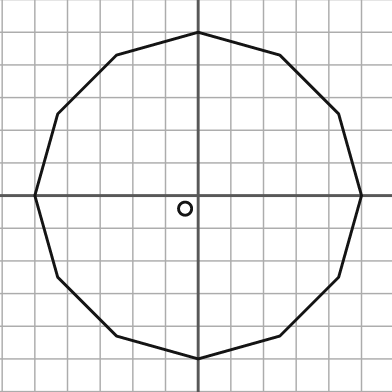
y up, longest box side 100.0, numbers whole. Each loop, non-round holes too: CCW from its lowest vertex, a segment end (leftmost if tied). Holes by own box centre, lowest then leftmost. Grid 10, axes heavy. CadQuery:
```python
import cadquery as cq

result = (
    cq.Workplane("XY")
    .moveTo(0.0, -50.0)
    .lineTo(25.0, -43.0)
    .lineTo(43.0, -25.0)
    .lineTo(50.0, 0.0)
    .lineTo(43.0, 25.0)
    .lineTo(25.0, 43.0)
    .lineTo(0.0, 50.0)
    .lineTo(-25.0, 43.0)
    .lineTo(-43.0, 25.0)
    .lineTo(-50.0, 0.0)
    .lineTo(-43.0, -25.0)
    .lineTo(-25.0, -43.0)
    .close()
    .moveTo(-4.0, -4.0)
    .circle(2.0)
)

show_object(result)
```